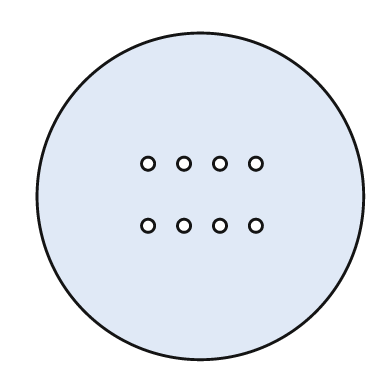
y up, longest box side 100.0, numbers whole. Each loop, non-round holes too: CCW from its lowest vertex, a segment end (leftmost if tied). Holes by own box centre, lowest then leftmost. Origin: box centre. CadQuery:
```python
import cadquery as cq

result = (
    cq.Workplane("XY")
    .moveTo(0.0, 0.0)
    .circle(50.0)
    .moveTo(-16.0, -9.0)
    .circle(2.0)
    .moveTo(-5.0, -9.0)
    .circle(2.0)
    .moveTo(6.0, -9.0)
    .circle(2.0)
    .moveTo(17.0, -9.0)
    .circle(2.0)
    .moveTo(-16.0, 10.0)
    .circle(2.0)
    .moveTo(-5.0, 10.0)
    .circle(2.0)
    .moveTo(6.0, 10.0)
    .circle(2.0)
    .moveTo(17.0, 10.0)
    .circle(2.0)
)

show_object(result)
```